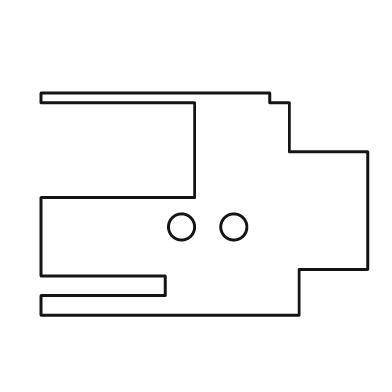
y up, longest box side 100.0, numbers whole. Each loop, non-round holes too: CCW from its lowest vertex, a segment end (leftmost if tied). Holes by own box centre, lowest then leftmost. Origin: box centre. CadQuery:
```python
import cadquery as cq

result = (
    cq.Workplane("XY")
    .moveTo(-50.0, -34.0)
    .lineTo(29.0, -34.0)
    .lineTo(29.0, -20.0)
    .lineTo(50.0, -20.0)
    .lineTo(50.0, 16.0)
    .lineTo(26.0, 16.0)
    .lineTo(26.0, 31.0)
    .lineTo(20.0, 31.0)
    .lineTo(20.0, 34.0)
    .lineTo(-50.0, 34.0)
    .lineTo(-50.0, 31.0)
    .lineTo(-3.0, 31.0)
    .lineTo(-3.0, 2.0)
    .lineTo(-50.0, 2.0)
    .lineTo(-50.0, -22.0)
    .lineTo(-12.0, -22.0)
    .lineTo(-12.0, -28.0)
    .lineTo(-50.0, -28.0)
    .close()
    .moveTo(-7.0, -7.0)
    .circle(4.0)
    .moveTo(9.0, -7.0)
    .circle(4.0)
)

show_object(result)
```